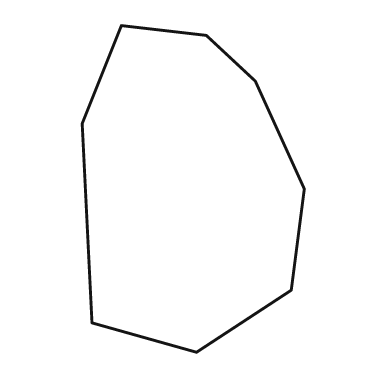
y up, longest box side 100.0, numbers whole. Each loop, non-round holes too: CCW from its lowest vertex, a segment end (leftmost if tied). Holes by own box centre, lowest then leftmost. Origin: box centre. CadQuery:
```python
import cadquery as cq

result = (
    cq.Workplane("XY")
    .moveTo(1.0, -50.0)
    .lineTo(30.0, -31.0)
    .lineTo(34.0, 0.0)
    .lineTo(19.0, 33.0)
    .lineTo(4.0, 47.0)
    .lineTo(-22.0, 50.0)
    .lineTo(-34.0, 20.0)
    .lineTo(-31.0, -41.0)
    .close()
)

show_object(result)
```